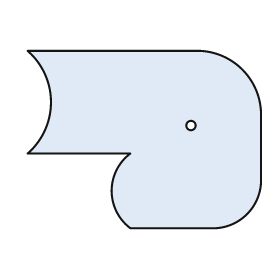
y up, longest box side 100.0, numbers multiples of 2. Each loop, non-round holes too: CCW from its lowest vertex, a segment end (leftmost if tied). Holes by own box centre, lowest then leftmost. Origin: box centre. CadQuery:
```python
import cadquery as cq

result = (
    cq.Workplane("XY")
    .moveTo(-6.0, -38.0)
    .lineTo(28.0, -38.0)
    .threePointArc((44.0, -32.0), (50.0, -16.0))
    .lineTo(50.0, 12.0)
    .threePointArc((42.0, 30.0), (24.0, 38.0))
    .lineTo(-50.0, 38.0)
    .threePointArc((-40.0, 16.0), (-50.0, -6.0))
    .lineTo(-6.0, -6.0)
    .threePointArc((-14.0, -22.0), (-6.0, -38.0))
    .close()
    .moveTo(20.0, 6.0)
    .circle(2.0)
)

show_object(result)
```